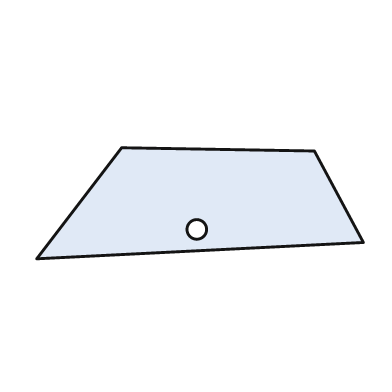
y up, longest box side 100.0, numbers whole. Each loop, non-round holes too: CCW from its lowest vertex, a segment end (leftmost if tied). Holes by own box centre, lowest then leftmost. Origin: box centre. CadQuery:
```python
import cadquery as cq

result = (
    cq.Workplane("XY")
    .moveTo(-50.0, -17.0)
    .lineTo(50.0, -12.0)
    .lineTo(35.0, 16.0)
    .lineTo(-24.0, 17.0)
    .close()
    .moveTo(-1.0, -8.0)
    .circle(3.0)
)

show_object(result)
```